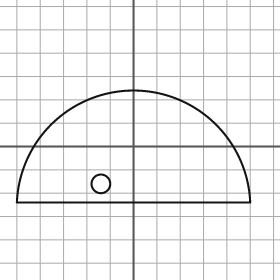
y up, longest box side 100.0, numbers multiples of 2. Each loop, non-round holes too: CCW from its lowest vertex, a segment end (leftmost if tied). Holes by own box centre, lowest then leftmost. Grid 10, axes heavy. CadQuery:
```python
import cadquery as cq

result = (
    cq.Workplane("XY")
    .moveTo(-50.0, -24.0)
    .lineTo(50.0, -24.0)
    .threePointArc((0.0, 24.0), (-50.0, -24.0))
    .close()
    .moveTo(-14.0, -16.0)
    .circle(4.0)
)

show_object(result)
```